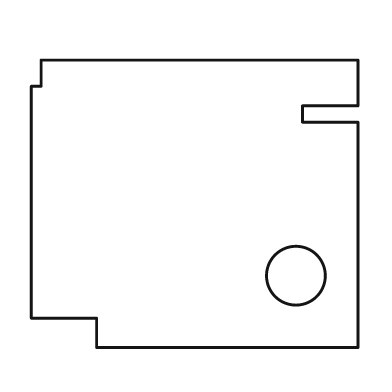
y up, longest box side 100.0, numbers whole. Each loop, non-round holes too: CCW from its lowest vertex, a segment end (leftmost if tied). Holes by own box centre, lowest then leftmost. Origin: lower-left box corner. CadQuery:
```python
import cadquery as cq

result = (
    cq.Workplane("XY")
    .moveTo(20.0, 0.0)
    .lineTo(100.0, 0.0)
    .lineTo(100.0, 69.0)
    .lineTo(83.0, 69.0)
    .lineTo(83.0, 74.0)
    .lineTo(100.0, 74.0)
    .lineTo(100.0, 88.0)
    .lineTo(3.0, 88.0)
    .lineTo(3.0, 80.0)
    .lineTo(0.0, 80.0)
    .lineTo(0.0, 9.0)
    .lineTo(20.0, 9.0)
    .close()
    .moveTo(81.0, 22.0)
    .circle(9.0)
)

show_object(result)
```